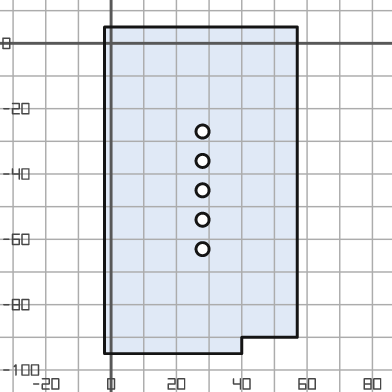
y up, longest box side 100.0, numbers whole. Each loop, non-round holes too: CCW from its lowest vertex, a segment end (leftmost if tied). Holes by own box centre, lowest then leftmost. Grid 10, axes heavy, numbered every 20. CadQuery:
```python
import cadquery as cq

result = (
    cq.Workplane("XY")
    .moveTo(-2.0, -95.0)
    .lineTo(40.0, -95.0)
    .lineTo(40.0, -90.0)
    .lineTo(57.0, -90.0)
    .lineTo(57.0, 5.0)
    .lineTo(-2.0, 5.0)
    .close()
    .moveTo(28.0, -63.0)
    .circle(2.0)
    .moveTo(28.0, -54.0)
    .circle(2.0)
    .moveTo(28.0, -45.0)
    .circle(2.0)
    .moveTo(28.0, -36.0)
    .circle(2.0)
    .moveTo(28.0, -27.0)
    .circle(2.0)
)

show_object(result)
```